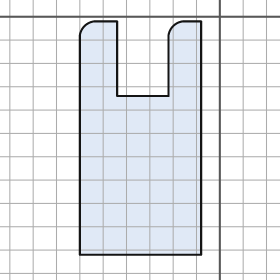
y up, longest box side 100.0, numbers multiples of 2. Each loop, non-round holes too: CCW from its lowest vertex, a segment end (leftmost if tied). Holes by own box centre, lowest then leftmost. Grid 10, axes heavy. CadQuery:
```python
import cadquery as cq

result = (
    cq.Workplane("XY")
    .moveTo(-60.0, -102.0)
    .lineTo(-8.0, -102.0)
    .lineTo(-8.0, -2.0)
    .lineTo(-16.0, -2.0)
    .threePointArc((-20.0, -4.0), (-22.0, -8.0))
    .lineTo(-22.0, -34.0)
    .lineTo(-44.0, -34.0)
    .lineTo(-44.0, -2.0)
    .lineTo(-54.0, -2.0)
    .threePointArc((-58.0, -4.0), (-60.0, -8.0))
    .close()
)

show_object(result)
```